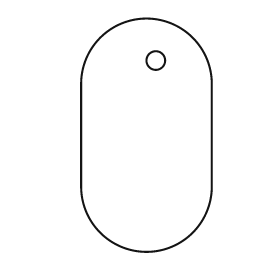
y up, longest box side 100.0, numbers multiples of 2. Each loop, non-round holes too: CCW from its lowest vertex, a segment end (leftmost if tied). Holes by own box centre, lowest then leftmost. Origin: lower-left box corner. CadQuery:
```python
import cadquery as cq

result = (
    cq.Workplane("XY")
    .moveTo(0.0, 28.0)
    .threePointArc((28.0, 0.0), (56.0, 28.0))
    .lineTo(56.0, 72.0)
    .threePointArc((28.0, 100.0), (0.0, 72.0))
    .close()
    .moveTo(32.0, 82.0)
    .circle(4.0)
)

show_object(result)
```